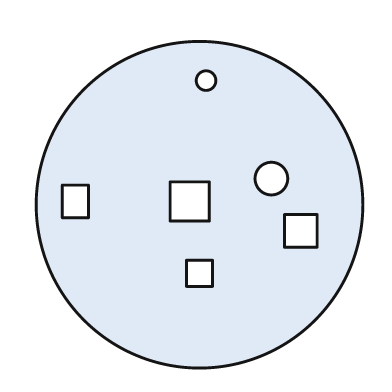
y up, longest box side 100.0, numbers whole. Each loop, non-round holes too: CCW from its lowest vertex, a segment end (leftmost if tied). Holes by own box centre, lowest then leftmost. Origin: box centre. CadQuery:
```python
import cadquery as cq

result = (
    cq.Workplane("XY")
    .moveTo(0.0, 0.0)
    .circle(50.0)
    .moveTo(-4.0, -25.0)
    .lineTo(4.0, -25.0)
    .lineTo(4.0, -17.0)
    .lineTo(-4.0, -17.0)
    .close()
    .moveTo(26.0, -13.0)
    .lineTo(36.0, -13.0)
    .lineTo(36.0, -3.0)
    .lineTo(26.0, -3.0)
    .close()
    .moveTo(-42.0, -4.0)
    .lineTo(-34.0, -4.0)
    .lineTo(-34.0, 6.0)
    .lineTo(-42.0, 6.0)
    .close()
    .moveTo(-9.0, -5.0)
    .lineTo(3.0, -5.0)
    .lineTo(3.0, 7.0)
    .lineTo(-9.0, 7.0)
    .close()
    .moveTo(22.0, 8.0)
    .circle(5.0)
    .moveTo(2.0, 38.0)
    .circle(3.0)
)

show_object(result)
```